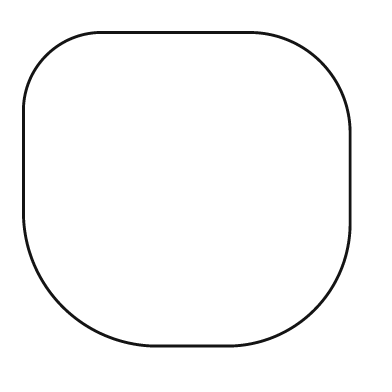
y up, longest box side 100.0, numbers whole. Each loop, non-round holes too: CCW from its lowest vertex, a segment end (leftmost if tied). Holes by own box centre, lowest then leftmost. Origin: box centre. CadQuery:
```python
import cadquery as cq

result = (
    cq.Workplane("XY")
    .moveTo(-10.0, -48.0)
    .lineTo(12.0, -48.0)
    .threePointArc((39.0, -37.0), (50.0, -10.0))
    .lineTo(50.0, 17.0)
    .threePointArc((41.0, 39.0), (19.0, 48.0))
    .lineTo(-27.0, 48.0)
    .threePointArc((-43.0, 41.0), (-50.0, 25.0))
    .lineTo(-50.0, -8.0)
    .threePointArc((-38.0, -36.0), (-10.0, -48.0))
    .close()
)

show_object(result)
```